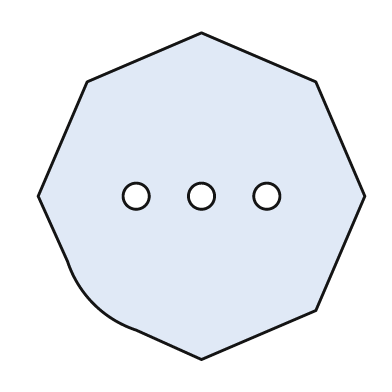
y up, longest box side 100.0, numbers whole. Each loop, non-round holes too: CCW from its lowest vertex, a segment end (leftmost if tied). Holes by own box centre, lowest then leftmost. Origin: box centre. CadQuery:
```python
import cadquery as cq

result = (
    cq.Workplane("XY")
    .moveTo(0.0, -50.0)
    .lineTo(35.0, -35.0)
    .lineTo(50.0, 0.0)
    .lineTo(35.0, 35.0)
    .lineTo(0.0, 50.0)
    .lineTo(-35.0, 35.0)
    .lineTo(-50.0, 0.0)
    .lineTo(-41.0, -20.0)
    .threePointArc((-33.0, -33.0), (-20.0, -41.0))
    .close()
    .moveTo(-20.0, 0.0)
    .circle(4.0)
    .moveTo(0.0, 0.0)
    .circle(4.0)
    .moveTo(20.0, 0.0)
    .circle(4.0)
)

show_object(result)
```